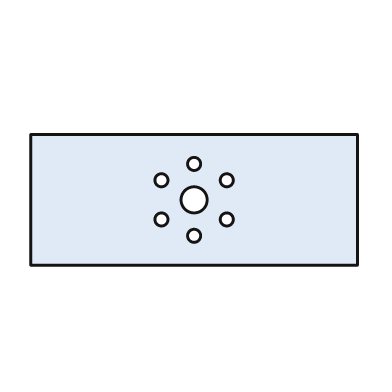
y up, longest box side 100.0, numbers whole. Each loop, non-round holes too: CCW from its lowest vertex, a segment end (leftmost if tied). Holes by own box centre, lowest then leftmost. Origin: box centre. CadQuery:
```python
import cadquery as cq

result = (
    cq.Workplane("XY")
    .moveTo(-50.0, -20.0)
    .lineTo(50.0, -20.0)
    .lineTo(50.0, 20.0)
    .lineTo(-50.0, 20.0)
    .close()
    .moveTo(0.0, -11.0)
    .circle(2.0)
    .moveTo(-10.0, -6.0)
    .circle(2.0)
    .moveTo(10.0, -6.0)
    .circle(2.0)
    .moveTo(0.0, 0.0)
    .circle(4.0)
    .moveTo(-10.0, 6.0)
    .circle(2.0)
    .moveTo(10.0, 6.0)
    .circle(2.0)
    .moveTo(0.0, 11.0)
    .circle(2.0)
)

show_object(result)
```